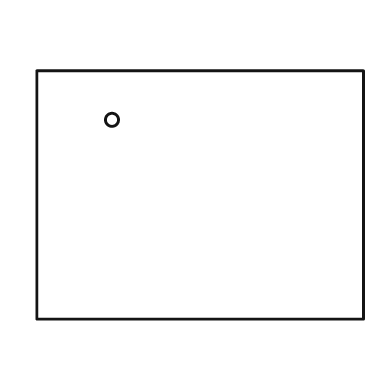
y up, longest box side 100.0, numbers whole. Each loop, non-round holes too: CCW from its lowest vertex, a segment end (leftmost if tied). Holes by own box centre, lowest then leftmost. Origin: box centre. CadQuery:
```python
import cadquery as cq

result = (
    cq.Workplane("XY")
    .moveTo(-50.0, -38.0)
    .lineTo(50.0, -38.0)
    .lineTo(50.0, 38.0)
    .lineTo(-50.0, 38.0)
    .close()
    .moveTo(-27.0, 23.0)
    .circle(2.0)
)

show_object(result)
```